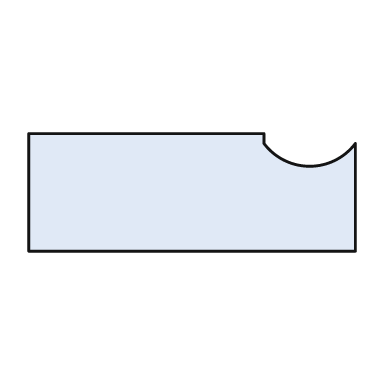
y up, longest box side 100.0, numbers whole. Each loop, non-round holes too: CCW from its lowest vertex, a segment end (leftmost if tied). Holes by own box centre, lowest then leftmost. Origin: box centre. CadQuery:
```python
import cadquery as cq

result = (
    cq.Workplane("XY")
    .moveTo(-50.0, -18.0)
    .lineTo(50.0, -18.0)
    .lineTo(50.0, 15.0)
    .threePointArc((36.0, 8.0), (22.0, 15.0))
    .lineTo(22.0, 18.0)
    .lineTo(-50.0, 18.0)
    .close()
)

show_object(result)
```